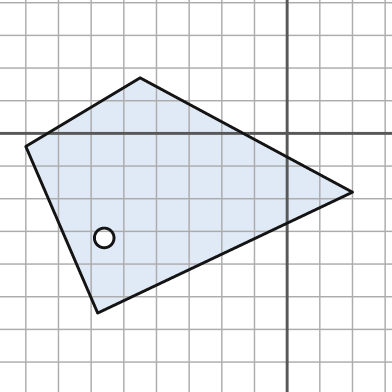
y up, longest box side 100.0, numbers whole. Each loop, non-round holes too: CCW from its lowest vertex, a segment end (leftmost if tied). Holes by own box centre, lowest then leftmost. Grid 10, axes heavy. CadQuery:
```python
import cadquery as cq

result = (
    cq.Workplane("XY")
    .moveTo(-58.0, -55.0)
    .lineTo(20.0, -18.0)
    .lineTo(-45.0, 17.0)
    .lineTo(-80.0, -4.0)
    .close()
    .moveTo(-56.0, -32.0)
    .circle(3.0)
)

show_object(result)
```